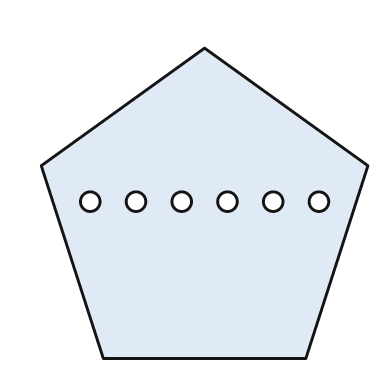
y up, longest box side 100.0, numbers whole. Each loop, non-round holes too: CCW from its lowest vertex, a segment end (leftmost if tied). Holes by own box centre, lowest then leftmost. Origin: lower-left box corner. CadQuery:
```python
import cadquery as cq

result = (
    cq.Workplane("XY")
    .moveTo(19.0, 0.0)
    .lineTo(81.0, 0.0)
    .lineTo(100.0, 59.0)
    .lineTo(50.0, 95.0)
    .lineTo(0.0, 59.0)
    .close()
    .moveTo(15.0, 48.0)
    .circle(3.0)
    .moveTo(29.0, 48.0)
    .circle(3.0)
    .moveTo(43.0, 48.0)
    .circle(3.0)
    .moveTo(57.0, 48.0)
    .circle(3.0)
    .moveTo(71.0, 48.0)
    .circle(3.0)
    .moveTo(85.0, 48.0)
    .circle(3.0)
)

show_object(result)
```